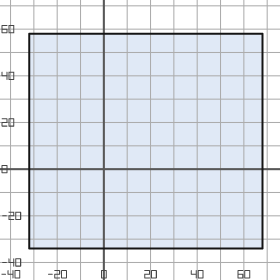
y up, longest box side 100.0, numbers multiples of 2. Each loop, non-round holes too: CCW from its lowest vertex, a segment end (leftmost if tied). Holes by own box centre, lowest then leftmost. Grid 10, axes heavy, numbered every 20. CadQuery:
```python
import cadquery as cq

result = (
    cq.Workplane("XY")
    .moveTo(-32.0, -34.0)
    .lineTo(68.0, -34.0)
    .lineTo(68.0, 58.0)
    .lineTo(-32.0, 58.0)
    .close()
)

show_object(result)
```